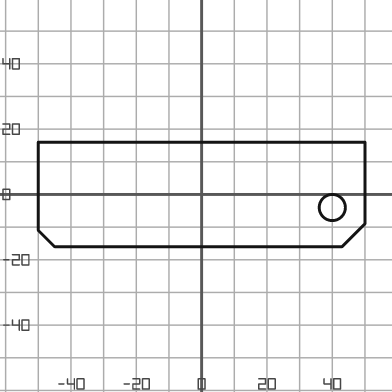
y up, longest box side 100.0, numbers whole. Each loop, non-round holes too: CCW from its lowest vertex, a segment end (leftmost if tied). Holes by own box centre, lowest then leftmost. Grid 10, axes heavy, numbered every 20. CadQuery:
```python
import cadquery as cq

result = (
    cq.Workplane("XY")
    .moveTo(-45.0, -16.0)
    .lineTo(43.0, -16.0)
    .lineTo(50.0, -9.0)
    .lineTo(50.0, 16.0)
    .lineTo(-50.0, 16.0)
    .lineTo(-50.0, -11.0)
    .close()
    .moveTo(40.0, -4.0)
    .circle(4.0)
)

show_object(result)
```